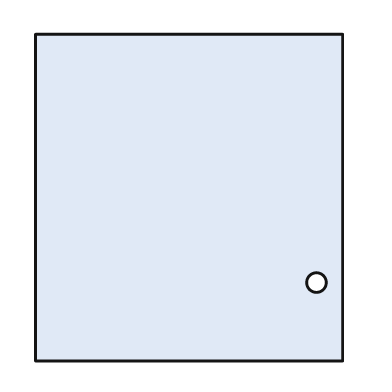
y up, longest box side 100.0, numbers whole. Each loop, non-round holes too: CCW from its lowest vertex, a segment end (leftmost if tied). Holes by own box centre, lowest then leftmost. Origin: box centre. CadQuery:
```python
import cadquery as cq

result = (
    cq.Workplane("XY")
    .moveTo(-47.0, -50.0)
    .lineTo(47.0, -50.0)
    .lineTo(47.0, 50.0)
    .lineTo(-47.0, 50.0)
    .close()
    .moveTo(39.0, -26.0)
    .circle(3.0)
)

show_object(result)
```